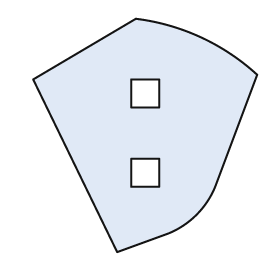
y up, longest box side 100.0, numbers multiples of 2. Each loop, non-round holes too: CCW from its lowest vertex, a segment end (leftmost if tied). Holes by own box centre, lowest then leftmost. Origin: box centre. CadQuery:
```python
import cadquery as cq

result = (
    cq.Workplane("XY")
    .moveTo(-12.0, -50.0)
    .lineTo(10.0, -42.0)
    .threePointArc((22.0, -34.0), (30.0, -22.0))
    .lineTo(48.0, 26.0)
    .threePointArc((24.0, 42.0), (-4.0, 50.0))
    .lineTo(-48.0, 24.0)
    .close()
    .moveTo(-6.0, -22.0)
    .lineTo(6.0, -22.0)
    .lineTo(6.0, -10.0)
    .lineTo(-6.0, -10.0)
    .close()
    .moveTo(-6.0, 12.0)
    .lineTo(6.0, 12.0)
    .lineTo(6.0, 24.0)
    .lineTo(-6.0, 24.0)
    .close()
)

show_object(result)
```